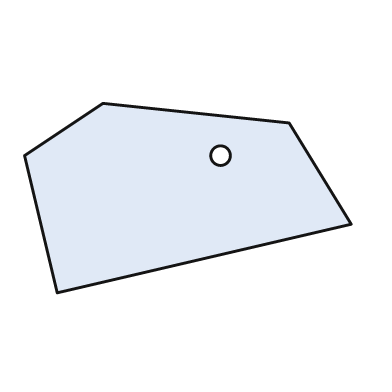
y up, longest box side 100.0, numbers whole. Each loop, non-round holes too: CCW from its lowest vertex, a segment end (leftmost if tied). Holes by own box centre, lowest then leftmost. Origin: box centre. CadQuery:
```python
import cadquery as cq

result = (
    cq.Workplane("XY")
    .moveTo(-40.0, -29.0)
    .lineTo(50.0, -8.0)
    .lineTo(31.0, 23.0)
    .lineTo(-26.0, 29.0)
    .lineTo(-50.0, 13.0)
    .close()
    .moveTo(10.0, 13.0)
    .circle(3.0)
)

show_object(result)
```